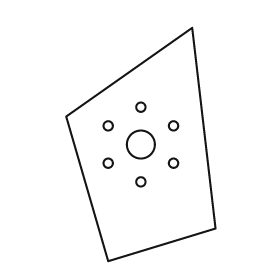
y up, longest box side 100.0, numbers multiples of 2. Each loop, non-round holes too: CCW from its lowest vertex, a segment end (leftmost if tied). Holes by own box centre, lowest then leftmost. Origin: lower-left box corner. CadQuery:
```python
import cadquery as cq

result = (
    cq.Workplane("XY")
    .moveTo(18.0, 0.0)
    .lineTo(64.0, 14.0)
    .lineTo(54.0, 100.0)
    .lineTo(0.0, 62.0)
    .close()
    .moveTo(32.0, 34.0)
    .circle(2.0)
    .moveTo(18.0, 42.0)
    .circle(2.0)
    .moveTo(46.0, 42.0)
    .circle(2.0)
    .moveTo(32.0, 50.0)
    .circle(6.0)
    .moveTo(18.0, 58.0)
    .circle(2.0)
    .moveTo(46.0, 58.0)
    .circle(2.0)
    .moveTo(32.0, 66.0)
    .circle(2.0)
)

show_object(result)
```